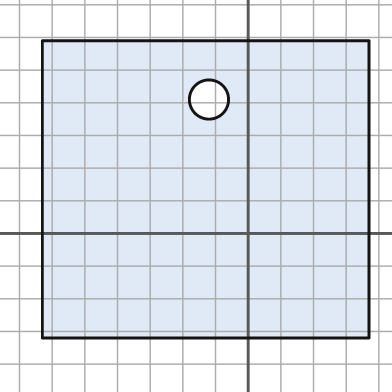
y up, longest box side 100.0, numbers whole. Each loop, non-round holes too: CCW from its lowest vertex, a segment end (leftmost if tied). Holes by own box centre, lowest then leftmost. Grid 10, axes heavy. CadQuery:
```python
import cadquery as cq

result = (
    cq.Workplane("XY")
    .moveTo(-63.0, -32.0)
    .lineTo(37.0, -32.0)
    .lineTo(37.0, 59.0)
    .lineTo(-63.0, 59.0)
    .close()
    .moveTo(-12.0, 41.0)
    .circle(6.0)
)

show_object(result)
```